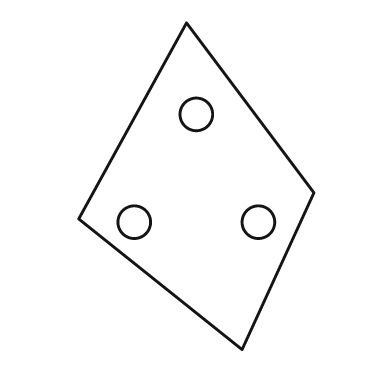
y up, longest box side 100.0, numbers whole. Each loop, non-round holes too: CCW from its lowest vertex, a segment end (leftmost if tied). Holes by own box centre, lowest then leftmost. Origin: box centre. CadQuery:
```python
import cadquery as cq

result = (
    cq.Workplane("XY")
    .moveTo(14.0, -50.0)
    .lineTo(36.0, -2.0)
    .lineTo(-3.0, 50.0)
    .lineTo(-36.0, -10.0)
    .close()
    .moveTo(-19.0, -11.0)
    .circle(5.0)
    .moveTo(19.0, -11.0)
    .circle(5.0)
    .moveTo(0.0, 22.0)
    .circle(5.0)
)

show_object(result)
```